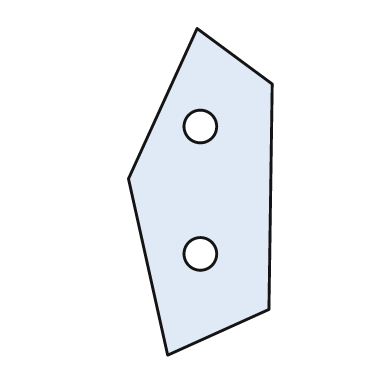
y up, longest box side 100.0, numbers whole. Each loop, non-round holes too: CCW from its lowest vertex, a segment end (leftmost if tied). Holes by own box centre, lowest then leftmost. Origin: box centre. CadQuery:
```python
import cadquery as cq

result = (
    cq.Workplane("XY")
    .moveTo(-10.0, -50.0)
    .lineTo(21.0, -36.0)
    .lineTo(22.0, 33.0)
    .lineTo(-1.0, 50.0)
    .lineTo(-22.0, 4.0)
    .close()
    .moveTo(0.0, -19.0)
    .circle(5.0)
    .moveTo(0.0, 20.0)
    .circle(5.0)
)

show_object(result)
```